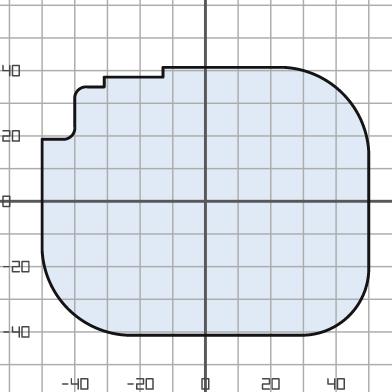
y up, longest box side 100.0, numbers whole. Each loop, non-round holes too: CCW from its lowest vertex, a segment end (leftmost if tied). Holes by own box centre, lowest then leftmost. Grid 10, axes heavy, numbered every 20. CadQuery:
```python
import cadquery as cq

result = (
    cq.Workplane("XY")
    .moveTo(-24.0, -41.0)
    .lineTo(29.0, -41.0)
    .threePointArc((44.0, -35.0), (50.0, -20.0))
    .lineTo(50.0, 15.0)
    .threePointArc((42.0, 33.0), (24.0, 41.0))
    .lineTo(-13.0, 41.0)
    .lineTo(-13.0, 38.0)
    .lineTo(-31.0, 38.0)
    .lineTo(-31.0, 35.0)
    .lineTo(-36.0, 35.0)
    .threePointArc((-39.0, 34.0), (-40.0, 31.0))
    .lineTo(-40.0, 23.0)
    .threePointArc((-41.0, 20.0), (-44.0, 19.0))
    .lineTo(-50.0, 19.0)
    .lineTo(-50.0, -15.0)
    .threePointArc((-42.0, -33.0), (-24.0, -41.0))
    .close()
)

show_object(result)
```